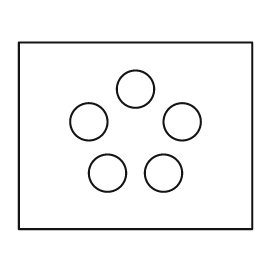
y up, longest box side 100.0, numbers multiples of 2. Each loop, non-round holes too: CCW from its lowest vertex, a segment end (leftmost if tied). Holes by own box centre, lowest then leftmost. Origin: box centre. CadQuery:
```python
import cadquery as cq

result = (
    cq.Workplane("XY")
    .moveTo(-50.0, -40.0)
    .lineTo(50.0, -40.0)
    .lineTo(50.0, 40.0)
    .lineTo(-50.0, 40.0)
    .close()
    .moveTo(-12.0, -16.0)
    .circle(8.0)
    .moveTo(12.0, -16.0)
    .circle(8.0)
    .moveTo(-20.0, 6.0)
    .circle(8.0)
    .moveTo(20.0, 6.0)
    .circle(8.0)
    .moveTo(0.0, 20.0)
    .circle(8.0)
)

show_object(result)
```